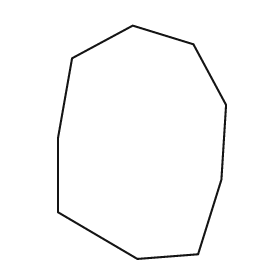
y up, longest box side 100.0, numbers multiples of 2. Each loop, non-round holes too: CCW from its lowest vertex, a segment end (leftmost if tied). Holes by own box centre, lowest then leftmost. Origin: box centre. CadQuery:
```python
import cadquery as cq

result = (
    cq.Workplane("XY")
    .moveTo(-2.0, -50.0)
    .lineTo(24.0, -48.0)
    .lineTo(34.0, -16.0)
    .lineTo(36.0, 16.0)
    .lineTo(22.0, 42.0)
    .lineTo(-4.0, 50.0)
    .lineTo(-30.0, 36.0)
    .lineTo(-36.0, 2.0)
    .lineTo(-36.0, -30.0)
    .close()
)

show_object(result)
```